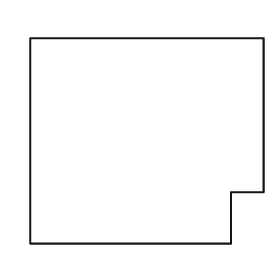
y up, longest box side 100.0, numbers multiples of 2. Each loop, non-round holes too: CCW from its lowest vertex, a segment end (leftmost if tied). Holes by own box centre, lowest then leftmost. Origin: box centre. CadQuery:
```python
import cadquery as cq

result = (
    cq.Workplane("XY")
    .moveTo(-50.0, -44.0)
    .lineTo(36.0, -44.0)
    .lineTo(36.0, -22.0)
    .lineTo(50.0, -22.0)
    .lineTo(50.0, 44.0)
    .lineTo(-50.0, 44.0)
    .close()
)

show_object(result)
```